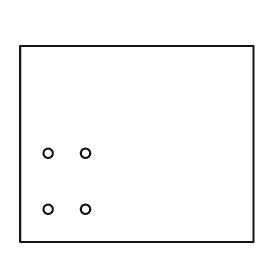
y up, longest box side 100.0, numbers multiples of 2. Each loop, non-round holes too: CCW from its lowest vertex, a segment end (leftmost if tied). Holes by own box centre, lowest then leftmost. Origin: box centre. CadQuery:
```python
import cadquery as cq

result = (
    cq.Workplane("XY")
    .moveTo(-50.0, -42.0)
    .lineTo(50.0, -42.0)
    .lineTo(50.0, 42.0)
    .lineTo(-50.0, 42.0)
    .close()
    .moveTo(-38.0, -28.0)
    .circle(2.0)
    .moveTo(-22.0, -28.0)
    .circle(2.0)
    .moveTo(-38.0, -4.0)
    .circle(2.0)
    .moveTo(-22.0, -4.0)
    .circle(2.0)
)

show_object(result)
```